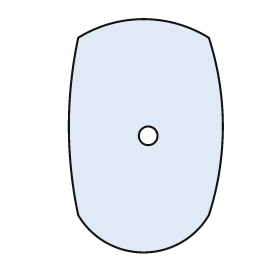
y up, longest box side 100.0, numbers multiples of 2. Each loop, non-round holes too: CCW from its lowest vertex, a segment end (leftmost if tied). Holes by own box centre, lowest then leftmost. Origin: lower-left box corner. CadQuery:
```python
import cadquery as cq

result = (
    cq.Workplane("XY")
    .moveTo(4.0, 16.0)
    .threePointArc((32.0, 0.0), (60.0, 16.0))
    .threePointArc((66.0, 54.0), (60.0, 92.0))
    .threePointArc((32.0, 100.0), (4.0, 92.0))
    .threePointArc((0.0, 54.0), (4.0, 16.0))
    .close()
    .moveTo(34.0, 50.0)
    .circle(4.0)
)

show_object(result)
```